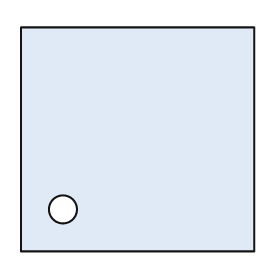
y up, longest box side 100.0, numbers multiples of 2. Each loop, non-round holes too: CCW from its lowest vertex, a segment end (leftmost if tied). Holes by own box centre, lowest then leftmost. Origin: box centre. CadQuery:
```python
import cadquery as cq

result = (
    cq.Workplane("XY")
    .moveTo(-50.0, -48.0)
    .lineTo(50.0, -48.0)
    .lineTo(50.0, 48.0)
    .lineTo(-50.0, 48.0)
    .close()
    .moveTo(-32.0, -30.0)
    .circle(6.0)
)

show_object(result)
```